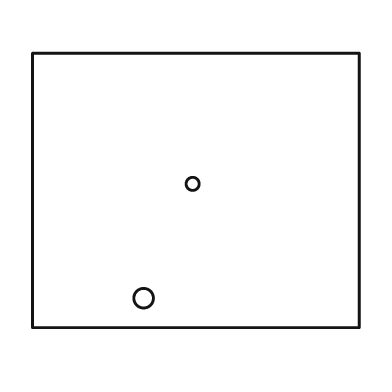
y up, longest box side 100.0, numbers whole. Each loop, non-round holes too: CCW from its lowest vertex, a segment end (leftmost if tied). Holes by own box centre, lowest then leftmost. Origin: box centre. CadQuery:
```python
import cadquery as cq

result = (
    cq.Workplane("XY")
    .moveTo(-50.0, -42.0)
    .lineTo(50.0, -42.0)
    .lineTo(50.0, 42.0)
    .lineTo(-50.0, 42.0)
    .close()
    .moveTo(-16.0, -33.0)
    .circle(3.0)
    .moveTo(-1.0, 2.0)
    .circle(2.0)
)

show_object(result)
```